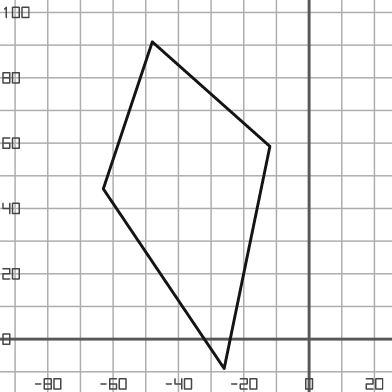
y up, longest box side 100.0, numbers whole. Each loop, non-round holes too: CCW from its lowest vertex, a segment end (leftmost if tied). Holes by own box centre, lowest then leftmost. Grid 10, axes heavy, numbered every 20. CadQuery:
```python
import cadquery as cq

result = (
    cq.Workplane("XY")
    .moveTo(-26.0, -9.0)
    .lineTo(-12.0, 59.0)
    .lineTo(-48.0, 91.0)
    .lineTo(-63.0, 46.0)
    .close()
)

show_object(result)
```